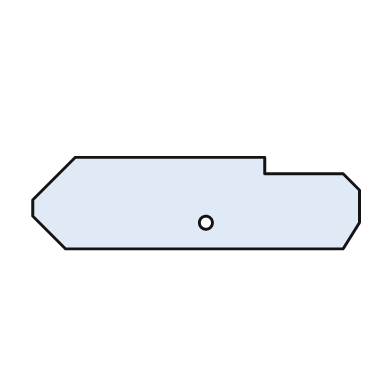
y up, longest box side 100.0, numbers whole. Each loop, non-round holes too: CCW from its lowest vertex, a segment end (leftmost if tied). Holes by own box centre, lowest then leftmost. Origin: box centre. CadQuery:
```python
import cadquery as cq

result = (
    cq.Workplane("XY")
    .moveTo(-40.0, -14.0)
    .lineTo(45.0, -14.0)
    .lineTo(50.0, -6.0)
    .lineTo(50.0, 4.0)
    .lineTo(45.0, 9.0)
    .lineTo(21.0, 9.0)
    .lineTo(21.0, 14.0)
    .lineTo(-37.0, 14.0)
    .lineTo(-50.0, 1.0)
    .lineTo(-50.0, -4.0)
    .close()
    .moveTo(3.0, -6.0)
    .circle(2.0)
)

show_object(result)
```